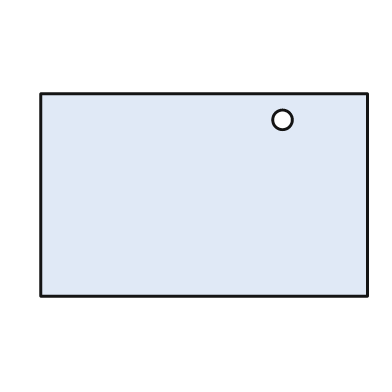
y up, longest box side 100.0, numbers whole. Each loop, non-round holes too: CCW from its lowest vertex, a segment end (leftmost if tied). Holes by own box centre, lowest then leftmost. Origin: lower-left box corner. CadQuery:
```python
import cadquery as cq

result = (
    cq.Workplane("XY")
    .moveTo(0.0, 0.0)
    .lineTo(100.0, 0.0)
    .lineTo(100.0, 62.0)
    .lineTo(0.0, 62.0)
    .close()
    .moveTo(74.0, 54.0)
    .circle(3.0)
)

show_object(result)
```